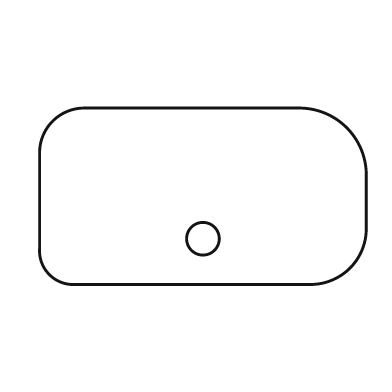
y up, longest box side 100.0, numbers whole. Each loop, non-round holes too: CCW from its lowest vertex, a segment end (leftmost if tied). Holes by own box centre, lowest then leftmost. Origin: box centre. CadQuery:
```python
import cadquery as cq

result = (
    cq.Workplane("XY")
    .moveTo(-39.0, -27.0)
    .lineTo(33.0, -27.0)
    .threePointArc((45.0, -22.0), (50.0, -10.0))
    .lineTo(50.0, 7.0)
    .threePointArc((44.0, 21.0), (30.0, 27.0))
    .lineTo(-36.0, 27.0)
    .threePointArc((-46.0, 23.0), (-50.0, 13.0))
    .lineTo(-50.0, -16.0)
    .threePointArc((-47.0, -24.0), (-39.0, -27.0))
    .close()
    .moveTo(0.0, -13.0)
    .circle(5.0)
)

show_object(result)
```